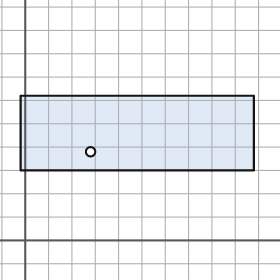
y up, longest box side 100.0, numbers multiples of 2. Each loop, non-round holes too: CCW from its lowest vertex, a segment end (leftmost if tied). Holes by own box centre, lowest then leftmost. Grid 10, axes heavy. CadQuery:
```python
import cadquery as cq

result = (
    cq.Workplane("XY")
    .moveTo(-2.0, 30.0)
    .lineTo(98.0, 30.0)
    .lineTo(98.0, 62.0)
    .lineTo(-2.0, 62.0)
    .close()
    .moveTo(28.0, 38.0)
    .circle(2.0)
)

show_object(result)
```